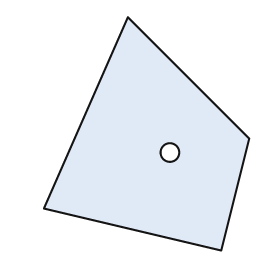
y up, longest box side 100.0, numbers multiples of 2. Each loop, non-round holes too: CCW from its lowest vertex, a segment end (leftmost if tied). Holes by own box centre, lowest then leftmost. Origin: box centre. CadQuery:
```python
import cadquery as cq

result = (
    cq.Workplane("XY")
    .moveTo(32.0, -50.0)
    .lineTo(44.0, -2.0)
    .lineTo(-8.0, 50.0)
    .lineTo(-44.0, -32.0)
    .close()
    .moveTo(10.0, -8.0)
    .circle(4.0)
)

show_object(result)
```